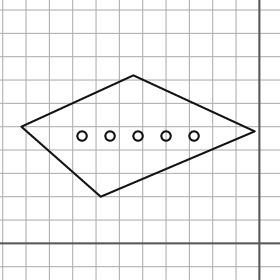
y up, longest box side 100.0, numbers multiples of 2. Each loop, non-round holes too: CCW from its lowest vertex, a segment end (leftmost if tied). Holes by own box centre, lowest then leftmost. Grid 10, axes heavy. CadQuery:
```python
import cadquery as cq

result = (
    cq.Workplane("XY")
    .moveTo(-68.0, 20.0)
    .lineTo(-2.0, 48.0)
    .lineTo(-54.0, 72.0)
    .lineTo(-102.0, 50.0)
    .close()
    .moveTo(-76.0, 46.0)
    .circle(2.0)
    .moveTo(-64.0, 46.0)
    .circle(2.0)
    .moveTo(-52.0, 46.0)
    .circle(2.0)
    .moveTo(-40.0, 46.0)
    .circle(2.0)
    .moveTo(-28.0, 46.0)
    .circle(2.0)
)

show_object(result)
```